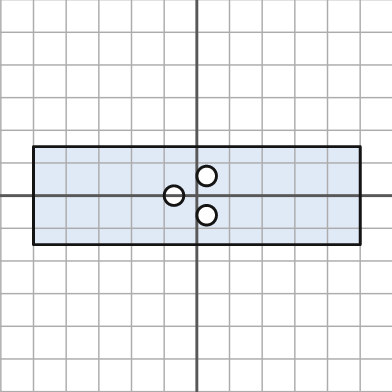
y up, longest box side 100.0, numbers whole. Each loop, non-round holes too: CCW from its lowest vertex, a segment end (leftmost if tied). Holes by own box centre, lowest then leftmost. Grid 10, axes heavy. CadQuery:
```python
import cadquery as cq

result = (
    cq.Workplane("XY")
    .moveTo(-50.0, -15.0)
    .lineTo(50.0, -15.0)
    .lineTo(50.0, 15.0)
    .lineTo(-50.0, 15.0)
    .close()
    .moveTo(3.0, -6.0)
    .circle(3.0)
    .moveTo(-7.0, 0.0)
    .circle(3.0)
    .moveTo(3.0, 6.0)
    .circle(3.0)
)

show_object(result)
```